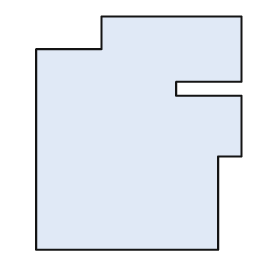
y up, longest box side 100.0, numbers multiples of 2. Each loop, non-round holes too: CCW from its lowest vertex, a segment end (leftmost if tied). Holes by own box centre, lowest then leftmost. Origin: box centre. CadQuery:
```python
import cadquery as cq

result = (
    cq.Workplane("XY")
    .moveTo(-44.0, -50.0)
    .lineTo(34.0, -50.0)
    .lineTo(34.0, -10.0)
    .lineTo(44.0, -10.0)
    .lineTo(44.0, 16.0)
    .lineTo(16.0, 16.0)
    .lineTo(16.0, 22.0)
    .lineTo(44.0, 22.0)
    .lineTo(44.0, 50.0)
    .lineTo(-16.0, 50.0)
    .lineTo(-16.0, 36.0)
    .lineTo(-44.0, 36.0)
    .close()
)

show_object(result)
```